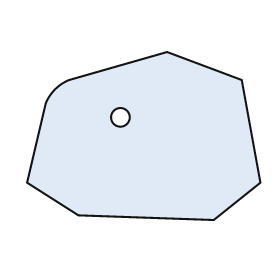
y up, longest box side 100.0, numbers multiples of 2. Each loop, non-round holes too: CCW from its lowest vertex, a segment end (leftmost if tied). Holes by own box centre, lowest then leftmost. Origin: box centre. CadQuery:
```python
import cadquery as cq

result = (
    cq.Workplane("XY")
    .moveTo(30.0, -36.0)
    .lineTo(50.0, -20.0)
    .lineTo(42.0, 24.0)
    .lineTo(10.0, 36.0)
    .lineTo(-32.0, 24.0)
    .threePointArc((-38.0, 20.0), (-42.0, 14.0))
    .lineTo(-50.0, -20.0)
    .lineTo(-28.0, -34.0)
    .close()
    .moveTo(-10.0, 8.0)
    .circle(4.0)
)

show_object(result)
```